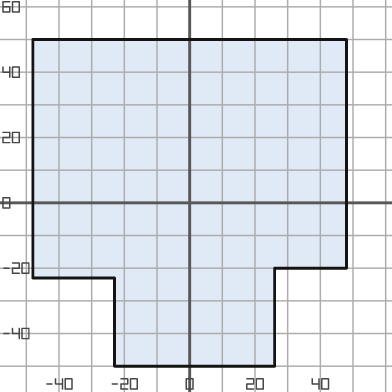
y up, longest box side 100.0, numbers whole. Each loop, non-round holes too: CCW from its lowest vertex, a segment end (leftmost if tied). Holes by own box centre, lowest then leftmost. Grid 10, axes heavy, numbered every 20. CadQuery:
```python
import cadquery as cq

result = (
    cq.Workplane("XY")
    .moveTo(-23.0, -50.0)
    .lineTo(26.0, -50.0)
    .lineTo(26.0, -20.0)
    .lineTo(48.0, -20.0)
    .lineTo(48.0, 50.0)
    .lineTo(-48.0, 50.0)
    .lineTo(-48.0, -23.0)
    .lineTo(-23.0, -23.0)
    .close()
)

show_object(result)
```